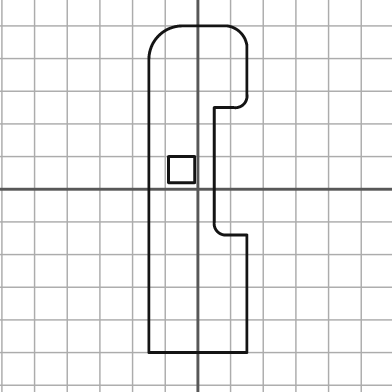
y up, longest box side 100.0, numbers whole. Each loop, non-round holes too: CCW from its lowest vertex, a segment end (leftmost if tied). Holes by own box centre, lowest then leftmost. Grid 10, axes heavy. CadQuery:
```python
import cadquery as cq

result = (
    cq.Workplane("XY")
    .moveTo(-15.0, -50.0)
    .lineTo(15.0, -50.0)
    .lineTo(15.0, -14.0)
    .lineTo(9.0, -14.0)
    .threePointArc((6.0, -13.0), (5.0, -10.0))
    .lineTo(5.0, 25.0)
    .lineTo(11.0, 25.0)
    .threePointArc((14.0, 26.0), (15.0, 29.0))
    .lineTo(15.0, 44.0)
    .threePointArc((13.0, 48.0), (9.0, 50.0))
    .lineTo(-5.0, 50.0)
    .threePointArc((-12.0, 47.0), (-15.0, 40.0))
    .close()
    .moveTo(-9.0, 2.0)
    .lineTo(-1.0, 2.0)
    .lineTo(-1.0, 10.0)
    .lineTo(-9.0, 10.0)
    .close()
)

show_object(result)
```